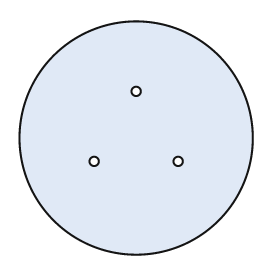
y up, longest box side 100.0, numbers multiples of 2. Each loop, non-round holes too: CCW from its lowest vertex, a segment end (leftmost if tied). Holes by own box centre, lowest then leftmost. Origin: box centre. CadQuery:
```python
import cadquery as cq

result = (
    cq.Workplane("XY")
    .moveTo(0.0, 0.0)
    .circle(50.0)
    .moveTo(-18.0, -10.0)
    .circle(2.0)
    .moveTo(18.0, -10.0)
    .circle(2.0)
    .moveTo(0.0, 20.0)
    .circle(2.0)
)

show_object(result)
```